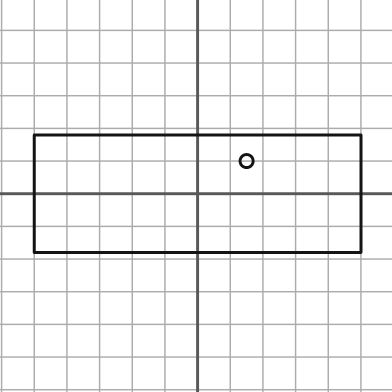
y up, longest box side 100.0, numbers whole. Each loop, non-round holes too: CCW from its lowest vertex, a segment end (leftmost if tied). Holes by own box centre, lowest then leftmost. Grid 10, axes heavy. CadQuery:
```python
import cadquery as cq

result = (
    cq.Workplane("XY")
    .moveTo(-50.0, -18.0)
    .lineTo(50.0, -18.0)
    .lineTo(50.0, 18.0)
    .lineTo(-50.0, 18.0)
    .close()
    .moveTo(15.0, 10.0)
    .circle(2.0)
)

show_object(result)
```